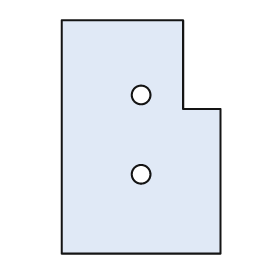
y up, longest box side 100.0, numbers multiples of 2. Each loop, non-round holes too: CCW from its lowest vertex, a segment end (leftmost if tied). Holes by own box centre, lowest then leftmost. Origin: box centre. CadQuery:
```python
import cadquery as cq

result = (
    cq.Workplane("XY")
    .moveTo(-34.0, -50.0)
    .lineTo(34.0, -50.0)
    .lineTo(34.0, 12.0)
    .lineTo(18.0, 12.0)
    .lineTo(18.0, 50.0)
    .lineTo(-34.0, 50.0)
    .close()
    .moveTo(0.0, -16.0)
    .circle(4.0)
    .moveTo(0.0, 18.0)
    .circle(4.0)
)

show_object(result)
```